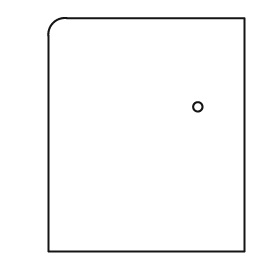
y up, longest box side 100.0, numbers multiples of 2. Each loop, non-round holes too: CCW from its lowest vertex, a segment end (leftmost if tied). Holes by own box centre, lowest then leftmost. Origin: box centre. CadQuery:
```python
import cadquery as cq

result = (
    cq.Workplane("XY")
    .moveTo(-42.0, -50.0)
    .lineTo(42.0, -50.0)
    .lineTo(42.0, 50.0)
    .lineTo(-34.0, 50.0)
    .threePointArc((-40.0, 48.0), (-42.0, 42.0))
    .close()
    .moveTo(22.0, 12.0)
    .circle(2.0)
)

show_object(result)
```